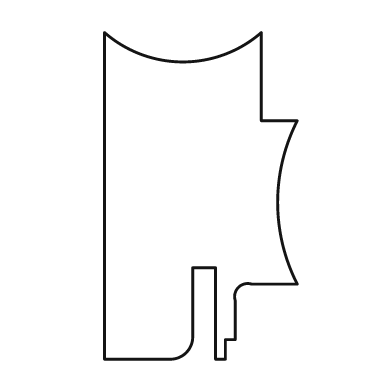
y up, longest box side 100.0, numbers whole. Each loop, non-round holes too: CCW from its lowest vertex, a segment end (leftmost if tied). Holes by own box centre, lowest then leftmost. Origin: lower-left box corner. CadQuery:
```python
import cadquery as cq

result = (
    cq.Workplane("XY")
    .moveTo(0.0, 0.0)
    .lineTo(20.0, 0.0)
    .threePointArc((25.0, 2.0), (27.0, 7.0))
    .lineTo(27.0, 28.0)
    .lineTo(34.0, 28.0)
    .lineTo(34.0, 0.0)
    .lineTo(37.0, 0.0)
    .lineTo(37.0, 6.0)
    .lineTo(40.0, 6.0)
    .lineTo(40.0, 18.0)
    .threePointArc((41.0, 22.0), (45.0, 23.0))
    .lineTo(59.0, 23.0)
    .threePointArc((53.0, 48.0), (59.0, 73.0))
    .lineTo(48.0, 73.0)
    .lineTo(48.0, 100.0)
    .threePointArc((24.0, 91.0), (0.0, 100.0))
    .close()
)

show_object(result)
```